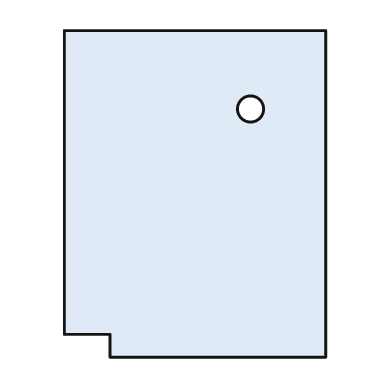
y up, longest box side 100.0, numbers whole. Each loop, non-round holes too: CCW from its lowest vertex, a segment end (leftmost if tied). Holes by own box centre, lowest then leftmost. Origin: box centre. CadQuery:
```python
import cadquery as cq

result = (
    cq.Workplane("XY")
    .moveTo(-26.0, -50.0)
    .lineTo(40.0, -50.0)
    .lineTo(40.0, 50.0)
    .lineTo(-40.0, 50.0)
    .lineTo(-40.0, -43.0)
    .lineTo(-26.0, -43.0)
    .close()
    .moveTo(17.0, 26.0)
    .circle(4.0)
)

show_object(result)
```